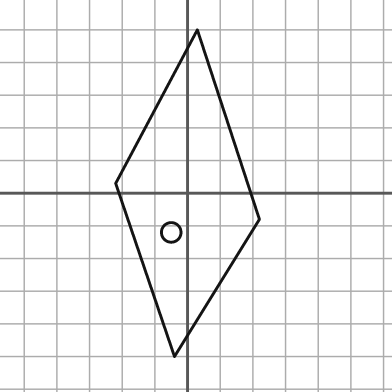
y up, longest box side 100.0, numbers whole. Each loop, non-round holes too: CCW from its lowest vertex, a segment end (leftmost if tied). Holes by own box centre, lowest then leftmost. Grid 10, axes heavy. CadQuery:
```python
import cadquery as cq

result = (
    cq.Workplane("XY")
    .moveTo(-4.0, -50.0)
    .lineTo(22.0, -8.0)
    .lineTo(3.0, 50.0)
    .lineTo(-22.0, 3.0)
    .close()
    .moveTo(-5.0, -12.0)
    .circle(3.0)
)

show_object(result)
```